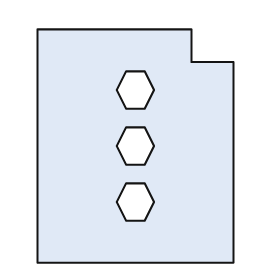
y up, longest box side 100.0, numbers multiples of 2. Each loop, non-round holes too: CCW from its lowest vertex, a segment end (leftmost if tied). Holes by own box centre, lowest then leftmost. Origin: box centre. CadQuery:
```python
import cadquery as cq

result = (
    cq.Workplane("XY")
    .moveTo(-42.0, -50.0)
    .lineTo(42.0, -50.0)
    .lineTo(42.0, 36.0)
    .lineTo(24.0, 36.0)
    .lineTo(24.0, 50.0)
    .lineTo(-42.0, 50.0)
    .close()
    .moveTo(-4.0, -32.0)
    .lineTo(4.0, -32.0)
    .lineTo(8.0, -24.0)
    .lineTo(4.0, -16.0)
    .lineTo(-4.0, -16.0)
    .lineTo(-8.0, -24.0)
    .close()
    .moveTo(-4.0, -8.0)
    .lineTo(4.0, -8.0)
    .lineTo(8.0, 0.0)
    .lineTo(4.0, 8.0)
    .lineTo(-4.0, 8.0)
    .lineTo(-8.0, 0.0)
    .close()
    .moveTo(-4.0, 16.0)
    .lineTo(4.0, 16.0)
    .lineTo(8.0, 24.0)
    .lineTo(4.0, 32.0)
    .lineTo(-4.0, 32.0)
    .lineTo(-8.0, 24.0)
    .close()
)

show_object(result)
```